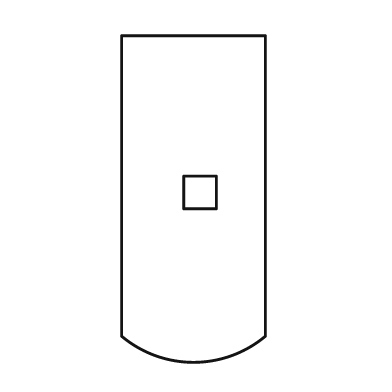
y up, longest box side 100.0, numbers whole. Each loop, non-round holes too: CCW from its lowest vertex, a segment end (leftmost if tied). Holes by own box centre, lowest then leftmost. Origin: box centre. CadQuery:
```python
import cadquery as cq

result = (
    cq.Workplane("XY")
    .moveTo(-22.0, -42.0)
    .threePointArc((0.0, -50.0), (22.0, -42.0))
    .lineTo(22.0, 50.0)
    .lineTo(-22.0, 50.0)
    .close()
    .moveTo(-3.0, -3.0)
    .lineTo(7.0, -3.0)
    .lineTo(7.0, 7.0)
    .lineTo(-3.0, 7.0)
    .close()
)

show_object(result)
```